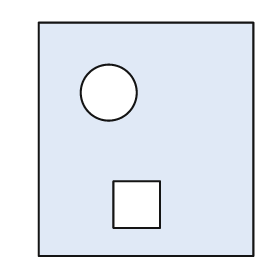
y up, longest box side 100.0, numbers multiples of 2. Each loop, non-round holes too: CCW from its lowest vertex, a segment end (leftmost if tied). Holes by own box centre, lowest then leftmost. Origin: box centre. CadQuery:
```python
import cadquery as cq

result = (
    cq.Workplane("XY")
    .moveTo(-46.0, -50.0)
    .lineTo(46.0, -50.0)
    .lineTo(46.0, 50.0)
    .lineTo(-46.0, 50.0)
    .close()
    .moveTo(-14.0, -38.0)
    .lineTo(6.0, -38.0)
    .lineTo(6.0, -18.0)
    .lineTo(-14.0, -18.0)
    .close()
    .moveTo(-16.0, 20.0)
    .circle(12.0)
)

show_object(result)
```